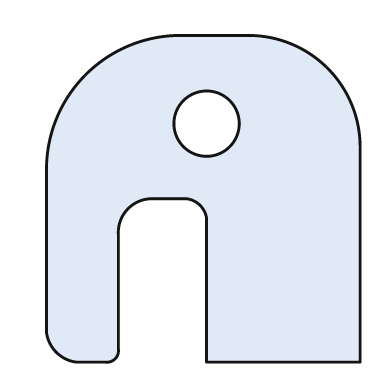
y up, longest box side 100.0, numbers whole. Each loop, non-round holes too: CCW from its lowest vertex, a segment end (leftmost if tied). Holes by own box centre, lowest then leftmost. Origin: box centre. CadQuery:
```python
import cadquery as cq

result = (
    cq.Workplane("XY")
    .moveTo(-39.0, -50.0)
    .lineTo(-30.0, -50.0)
    .threePointArc((-27.0, -49.0), (-26.0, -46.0))
    .lineTo(-26.0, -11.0)
    .threePointArc((-23.0, -3.0), (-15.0, 0.0))
    .lineTo(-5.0, 0.0)
    .threePointArc((-1.0, -2.0), (1.0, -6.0))
    .lineTo(1.0, -50.0)
    .lineTo(48.0, -50.0)
    .lineTo(48.0, 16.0)
    .threePointArc((38.0, 40.0), (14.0, 50.0))
    .lineTo(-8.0, 50.0)
    .threePointArc((-36.0, 38.0), (-48.0, 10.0))
    .lineTo(-48.0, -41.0)
    .threePointArc((-45.0, -47.0), (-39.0, -50.0))
    .close()
    .moveTo(1.0, 23.0)
    .circle(10.0)
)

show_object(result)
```